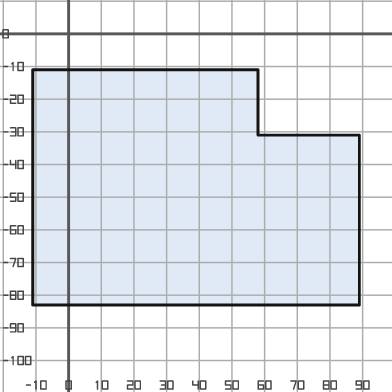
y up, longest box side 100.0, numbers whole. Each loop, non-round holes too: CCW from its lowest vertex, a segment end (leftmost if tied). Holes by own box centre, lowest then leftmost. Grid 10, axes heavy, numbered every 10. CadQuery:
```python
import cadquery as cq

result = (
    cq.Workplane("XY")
    .moveTo(-11.0, -83.0)
    .lineTo(89.0, -83.0)
    .lineTo(89.0, -31.0)
    .lineTo(58.0, -31.0)
    .lineTo(58.0, -11.0)
    .lineTo(-11.0, -11.0)
    .close()
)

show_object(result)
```